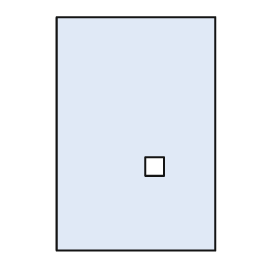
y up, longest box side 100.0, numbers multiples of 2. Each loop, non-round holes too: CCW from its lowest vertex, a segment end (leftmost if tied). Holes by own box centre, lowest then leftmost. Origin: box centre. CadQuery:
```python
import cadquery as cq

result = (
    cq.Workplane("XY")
    .moveTo(-34.0, -50.0)
    .lineTo(34.0, -50.0)
    .lineTo(34.0, 50.0)
    .lineTo(-34.0, 50.0)
    .close()
    .moveTo(4.0, -18.0)
    .lineTo(12.0, -18.0)
    .lineTo(12.0, -10.0)
    .lineTo(4.0, -10.0)
    .close()
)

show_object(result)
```